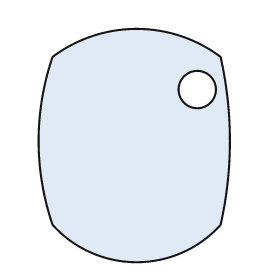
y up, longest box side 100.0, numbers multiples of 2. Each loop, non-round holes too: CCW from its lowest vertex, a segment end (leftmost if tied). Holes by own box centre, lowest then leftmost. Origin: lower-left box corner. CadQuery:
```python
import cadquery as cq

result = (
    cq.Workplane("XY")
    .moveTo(6.0, 16.0)
    .threePointArc((42.0, 0.0), (78.0, 16.0))
    .threePointArc((82.0, 52.0), (78.0, 88.0))
    .threePointArc((42.0, 100.0), (6.0, 88.0))
    .threePointArc((0.0, 52.0), (6.0, 16.0))
    .close()
    .moveTo(68.0, 74.0)
    .circle(8.0)
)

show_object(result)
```